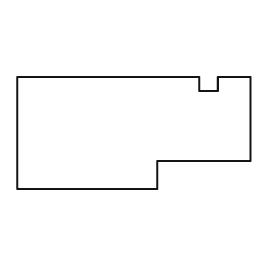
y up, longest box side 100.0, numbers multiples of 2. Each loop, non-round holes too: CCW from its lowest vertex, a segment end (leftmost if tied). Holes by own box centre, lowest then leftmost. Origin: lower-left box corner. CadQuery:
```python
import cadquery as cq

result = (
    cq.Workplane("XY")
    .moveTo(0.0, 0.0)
    .lineTo(60.0, 0.0)
    .lineTo(60.0, 12.0)
    .lineTo(100.0, 12.0)
    .lineTo(100.0, 48.0)
    .lineTo(86.0, 48.0)
    .lineTo(86.0, 42.0)
    .lineTo(78.0, 42.0)
    .lineTo(78.0, 48.0)
    .lineTo(0.0, 48.0)
    .close()
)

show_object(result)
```